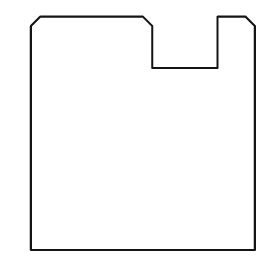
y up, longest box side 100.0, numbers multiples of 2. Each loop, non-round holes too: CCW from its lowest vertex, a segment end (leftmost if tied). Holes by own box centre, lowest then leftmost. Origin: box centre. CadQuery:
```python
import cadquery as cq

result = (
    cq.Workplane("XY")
    .moveTo(-48.0, -50.0)
    .lineTo(48.0, -50.0)
    .lineTo(48.0, 46.0)
    .lineTo(44.0, 50.0)
    .lineTo(32.0, 50.0)
    .lineTo(32.0, 28.0)
    .lineTo(4.0, 28.0)
    .lineTo(4.0, 46.0)
    .lineTo(0.0, 50.0)
    .lineTo(-44.0, 50.0)
    .lineTo(-48.0, 46.0)
    .close()
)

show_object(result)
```